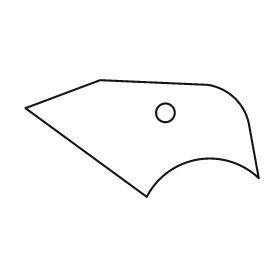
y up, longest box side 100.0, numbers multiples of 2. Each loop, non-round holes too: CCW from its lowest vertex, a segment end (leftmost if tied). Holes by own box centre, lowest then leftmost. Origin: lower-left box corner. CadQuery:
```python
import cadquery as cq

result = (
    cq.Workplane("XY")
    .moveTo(52.0, 0.0)
    .threePointArc((74.0, 16.0), (100.0, 8.0))
    .lineTo(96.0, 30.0)
    .threePointArc((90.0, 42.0), (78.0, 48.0))
    .lineTo(32.0, 50.0)
    .lineTo(0.0, 38.0)
    .close()
    .moveTo(60.0, 36.0)
    .circle(4.0)
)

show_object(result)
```